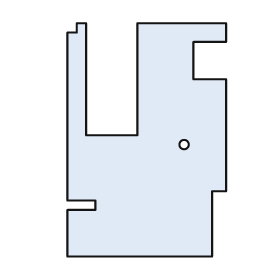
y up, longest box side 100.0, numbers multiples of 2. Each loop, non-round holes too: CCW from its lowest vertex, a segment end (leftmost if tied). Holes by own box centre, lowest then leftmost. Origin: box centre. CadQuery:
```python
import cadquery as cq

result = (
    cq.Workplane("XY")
    .moveTo(-34.0, -50.0)
    .lineTo(28.0, -50.0)
    .lineTo(28.0, -22.0)
    .lineTo(34.0, -22.0)
    .lineTo(34.0, 26.0)
    .lineTo(20.0, 26.0)
    .lineTo(20.0, 42.0)
    .lineTo(34.0, 42.0)
    .lineTo(34.0, 50.0)
    .lineTo(-4.0, 50.0)
    .lineTo(-4.0, 2.0)
    .lineTo(-26.0, 2.0)
    .lineTo(-26.0, 50.0)
    .lineTo(-30.0, 50.0)
    .lineTo(-30.0, 46.0)
    .lineTo(-34.0, 46.0)
    .lineTo(-34.0, -26.0)
    .lineTo(-22.0, -26.0)
    .lineTo(-22.0, -30.0)
    .lineTo(-34.0, -30.0)
    .close()
    .moveTo(16.0, -2.0)
    .circle(2.0)
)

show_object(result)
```